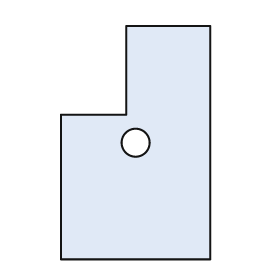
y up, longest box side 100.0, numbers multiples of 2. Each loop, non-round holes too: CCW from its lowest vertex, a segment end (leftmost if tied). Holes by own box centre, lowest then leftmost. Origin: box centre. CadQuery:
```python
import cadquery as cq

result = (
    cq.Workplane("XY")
    .moveTo(-32.0, -50.0)
    .lineTo(32.0, -50.0)
    .lineTo(32.0, 50.0)
    .lineTo(-4.0, 50.0)
    .lineTo(-4.0, 12.0)
    .lineTo(-32.0, 12.0)
    .close()
    .moveTo(0.0, 0.0)
    .circle(6.0)
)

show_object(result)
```